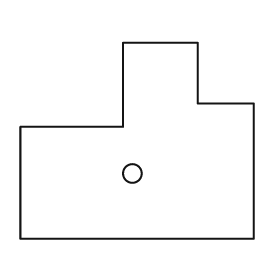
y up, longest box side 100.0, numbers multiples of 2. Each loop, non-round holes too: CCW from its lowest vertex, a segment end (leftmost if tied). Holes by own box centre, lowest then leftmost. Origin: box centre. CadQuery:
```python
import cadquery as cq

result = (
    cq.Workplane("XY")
    .moveTo(-50.0, -42.0)
    .lineTo(50.0, -42.0)
    .lineTo(50.0, 16.0)
    .lineTo(26.0, 16.0)
    .lineTo(26.0, 42.0)
    .lineTo(-6.0, 42.0)
    .lineTo(-6.0, 6.0)
    .lineTo(-50.0, 6.0)
    .close()
    .moveTo(-2.0, -14.0)
    .circle(4.0)
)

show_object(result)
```